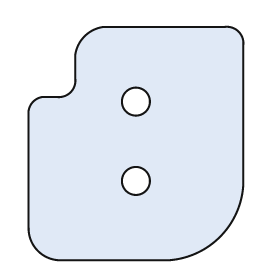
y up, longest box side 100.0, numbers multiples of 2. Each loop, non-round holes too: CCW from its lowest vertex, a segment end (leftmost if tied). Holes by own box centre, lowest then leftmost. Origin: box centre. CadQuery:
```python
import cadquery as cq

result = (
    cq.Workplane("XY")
    .moveTo(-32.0, -50.0)
    .lineTo(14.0, -50.0)
    .threePointArc((36.0, -40.0), (46.0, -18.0))
    .lineTo(46.0, 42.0)
    .threePointArc((44.0, 48.0), (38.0, 50.0))
    .lineTo(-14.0, 50.0)
    .threePointArc((-22.0, 46.0), (-26.0, 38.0))
    .lineTo(-26.0, 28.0)
    .threePointArc((-28.0, 22.0), (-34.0, 20.0))
    .lineTo(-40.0, 20.0)
    .threePointArc((-44.0, 18.0), (-46.0, 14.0))
    .lineTo(-46.0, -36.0)
    .threePointArc((-42.0, -46.0), (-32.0, -50.0))
    .close()
    .moveTo(0.0, -16.0)
    .circle(6.0)
    .moveTo(0.0, 18.0)
    .circle(6.0)
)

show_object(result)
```